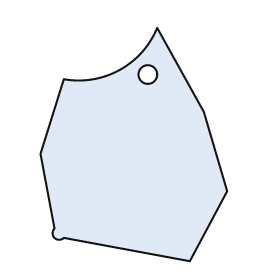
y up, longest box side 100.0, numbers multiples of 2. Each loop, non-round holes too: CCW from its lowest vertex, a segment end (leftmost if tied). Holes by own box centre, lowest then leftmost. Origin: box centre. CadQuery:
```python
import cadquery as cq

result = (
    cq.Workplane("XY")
    .moveTo(24.0, -50.0)
    .lineTo(40.0, -20.0)
    .lineTo(30.0, 14.0)
    .lineTo(10.0, 50.0)
    .threePointArc((-6.0, 32.0), (-30.0, 28.0))
    .lineTo(-40.0, -4.0)
    .lineTo(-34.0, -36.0)
    .threePointArc((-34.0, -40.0), (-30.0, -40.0))
    .close()
    .moveTo(6.0, 30.0)
    .circle(4.0)
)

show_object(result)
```